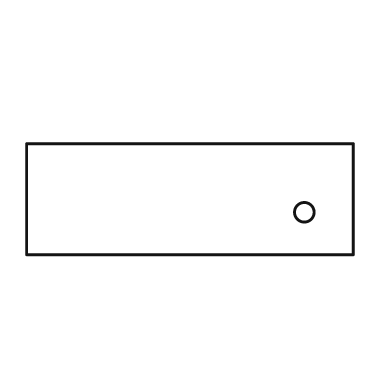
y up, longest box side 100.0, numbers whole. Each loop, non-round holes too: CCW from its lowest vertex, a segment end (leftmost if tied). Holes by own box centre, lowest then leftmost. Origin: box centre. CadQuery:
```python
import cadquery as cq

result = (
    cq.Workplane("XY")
    .moveTo(-50.0, -17.0)
    .lineTo(50.0, -17.0)
    .lineTo(50.0, 17.0)
    .lineTo(-50.0, 17.0)
    .close()
    .moveTo(35.0, -4.0)
    .circle(3.0)
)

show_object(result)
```